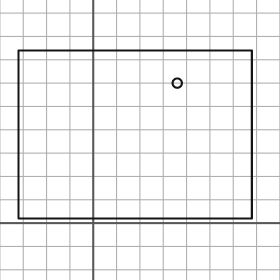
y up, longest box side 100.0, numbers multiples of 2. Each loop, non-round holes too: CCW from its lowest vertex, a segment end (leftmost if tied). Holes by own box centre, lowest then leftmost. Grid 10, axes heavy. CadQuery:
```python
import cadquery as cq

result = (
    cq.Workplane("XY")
    .moveTo(-32.0, 2.0)
    .lineTo(68.0, 2.0)
    .lineTo(68.0, 74.0)
    .lineTo(-32.0, 74.0)
    .close()
    .moveTo(36.0, 60.0)
    .circle(2.0)
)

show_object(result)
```